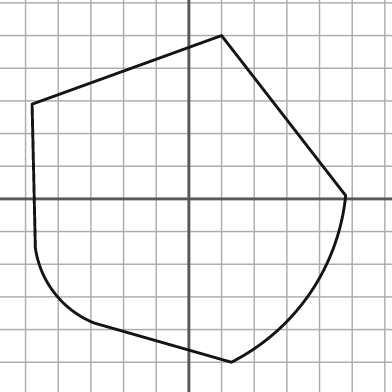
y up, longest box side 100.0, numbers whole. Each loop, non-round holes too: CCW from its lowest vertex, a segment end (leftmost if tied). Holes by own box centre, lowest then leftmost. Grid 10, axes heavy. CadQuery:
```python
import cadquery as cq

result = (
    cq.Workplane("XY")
    .moveTo(13.0, -50.0)
    .threePointArc((37.0, -29.0), (48.0, 1.0))
    .lineTo(10.0, 50.0)
    .lineTo(-48.0, 29.0)
    .lineTo(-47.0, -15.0)
    .threePointArc((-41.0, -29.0), (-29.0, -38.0))
    .close()
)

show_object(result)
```